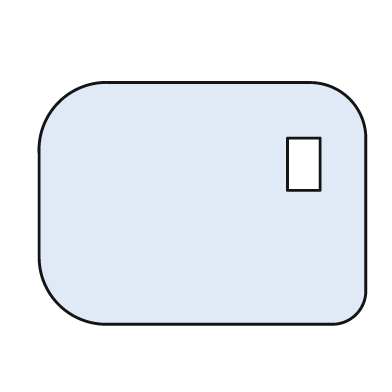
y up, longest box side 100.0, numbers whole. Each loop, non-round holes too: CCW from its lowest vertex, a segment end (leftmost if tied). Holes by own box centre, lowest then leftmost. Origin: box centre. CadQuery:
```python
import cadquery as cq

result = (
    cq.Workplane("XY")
    .moveTo(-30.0, -37.0)
    .lineTo(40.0, -37.0)
    .threePointArc((47.0, -34.0), (50.0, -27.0))
    .lineTo(50.0, 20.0)
    .threePointArc((45.0, 32.0), (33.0, 37.0))
    .lineTo(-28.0, 37.0)
    .threePointArc((-44.0, 31.0), (-50.0, 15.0))
    .lineTo(-50.0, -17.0)
    .threePointArc((-44.0, -31.0), (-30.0, -37.0))
    .close()
    .moveTo(26.0, 4.0)
    .lineTo(36.0, 4.0)
    .lineTo(36.0, 20.0)
    .lineTo(26.0, 20.0)
    .close()
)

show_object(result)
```